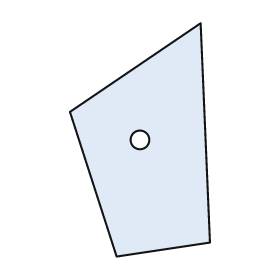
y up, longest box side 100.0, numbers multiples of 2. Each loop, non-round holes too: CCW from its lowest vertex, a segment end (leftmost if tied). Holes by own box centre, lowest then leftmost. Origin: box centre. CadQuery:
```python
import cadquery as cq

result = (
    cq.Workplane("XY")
    .moveTo(-10.0, -50.0)
    .lineTo(30.0, -44.0)
    .lineTo(26.0, 50.0)
    .lineTo(-30.0, 12.0)
    .close()
    .moveTo(0.0, 0.0)
    .circle(4.0)
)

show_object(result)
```